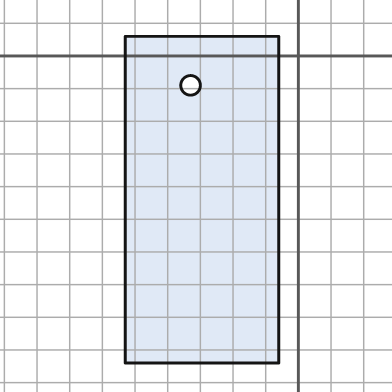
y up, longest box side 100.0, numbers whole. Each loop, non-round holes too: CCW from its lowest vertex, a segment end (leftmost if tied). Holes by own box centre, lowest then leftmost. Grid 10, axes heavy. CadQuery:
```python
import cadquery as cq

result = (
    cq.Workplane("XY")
    .moveTo(-53.0, -94.0)
    .lineTo(-6.0, -94.0)
    .lineTo(-6.0, 6.0)
    .lineTo(-53.0, 6.0)
    .close()
    .moveTo(-33.0, -9.0)
    .circle(3.0)
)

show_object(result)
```